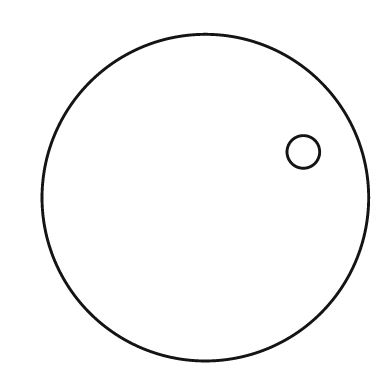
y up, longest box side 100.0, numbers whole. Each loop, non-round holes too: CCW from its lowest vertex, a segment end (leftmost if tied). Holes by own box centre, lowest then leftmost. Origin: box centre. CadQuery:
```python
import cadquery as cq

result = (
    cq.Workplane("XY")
    .moveTo(0.0, 0.0)
    .circle(50.0)
    .moveTo(30.0, 14.0)
    .circle(5.0)
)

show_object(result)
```